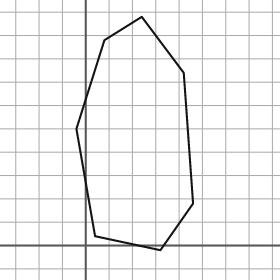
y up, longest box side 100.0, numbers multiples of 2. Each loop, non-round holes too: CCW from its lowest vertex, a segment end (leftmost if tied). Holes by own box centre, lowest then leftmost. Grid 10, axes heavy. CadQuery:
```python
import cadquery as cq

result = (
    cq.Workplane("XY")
    .moveTo(32.0, -2.0)
    .lineTo(46.0, 18.0)
    .lineTo(42.0, 74.0)
    .lineTo(24.0, 98.0)
    .lineTo(8.0, 88.0)
    .lineTo(-4.0, 50.0)
    .lineTo(4.0, 4.0)
    .close()
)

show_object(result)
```